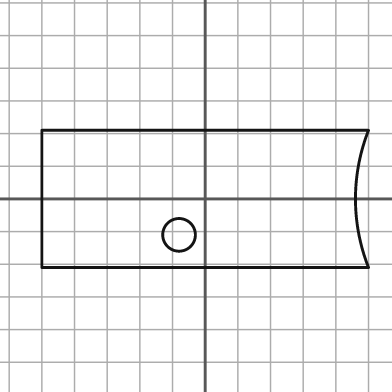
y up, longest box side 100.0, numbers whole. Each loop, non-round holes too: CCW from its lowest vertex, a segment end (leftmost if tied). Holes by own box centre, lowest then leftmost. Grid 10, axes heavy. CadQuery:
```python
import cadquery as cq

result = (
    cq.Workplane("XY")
    .moveTo(-50.0, -21.0)
    .lineTo(50.0, -21.0)
    .threePointArc((46.0, 0.0), (50.0, 21.0))
    .lineTo(-50.0, 21.0)
    .close()
    .moveTo(-8.0, -11.0)
    .circle(5.0)
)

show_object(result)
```